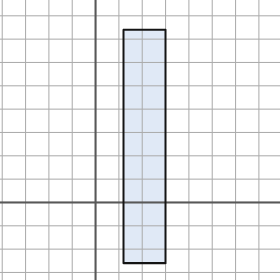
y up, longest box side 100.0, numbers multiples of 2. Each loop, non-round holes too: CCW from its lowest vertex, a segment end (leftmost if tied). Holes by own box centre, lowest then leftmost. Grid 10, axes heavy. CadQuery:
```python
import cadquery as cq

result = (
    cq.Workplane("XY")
    .moveTo(12.0, -26.0)
    .lineTo(30.0, -26.0)
    .lineTo(30.0, 74.0)
    .lineTo(12.0, 74.0)
    .close()
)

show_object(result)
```